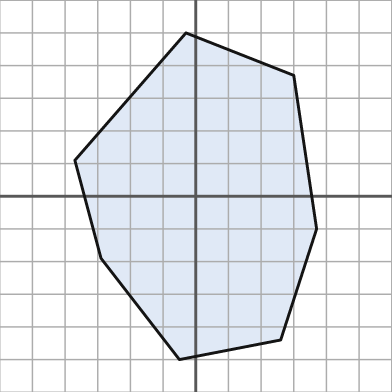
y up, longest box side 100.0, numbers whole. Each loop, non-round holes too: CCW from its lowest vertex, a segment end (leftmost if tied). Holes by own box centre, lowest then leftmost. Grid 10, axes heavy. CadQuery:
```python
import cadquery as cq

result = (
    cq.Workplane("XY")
    .moveTo(-5.0, -50.0)
    .lineTo(26.0, -44.0)
    .lineTo(37.0, -10.0)
    .lineTo(30.0, 37.0)
    .lineTo(-3.0, 50.0)
    .lineTo(-37.0, 11.0)
    .lineTo(-29.0, -19.0)
    .close()
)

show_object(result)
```